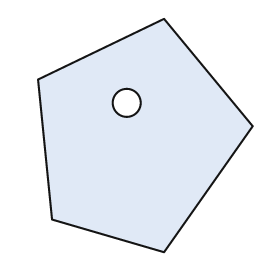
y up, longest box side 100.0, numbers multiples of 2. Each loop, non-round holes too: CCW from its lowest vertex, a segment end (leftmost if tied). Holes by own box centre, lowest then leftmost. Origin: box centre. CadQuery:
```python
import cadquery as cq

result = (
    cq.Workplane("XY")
    .moveTo(8.0, -50.0)
    .lineTo(46.0, 4.0)
    .lineTo(8.0, 50.0)
    .lineTo(-46.0, 24.0)
    .lineTo(-40.0, -36.0)
    .close()
    .moveTo(-8.0, 14.0)
    .circle(6.0)
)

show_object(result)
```